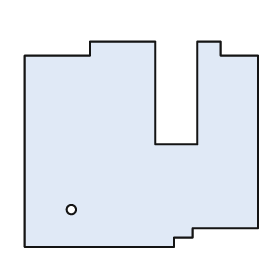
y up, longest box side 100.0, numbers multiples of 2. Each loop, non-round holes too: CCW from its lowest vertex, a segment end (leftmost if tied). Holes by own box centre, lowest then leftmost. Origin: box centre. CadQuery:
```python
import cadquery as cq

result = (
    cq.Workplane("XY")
    .moveTo(-50.0, -44.0)
    .lineTo(14.0, -44.0)
    .lineTo(14.0, -40.0)
    .lineTo(22.0, -40.0)
    .lineTo(22.0, -36.0)
    .lineTo(50.0, -36.0)
    .lineTo(50.0, 38.0)
    .lineTo(34.0, 38.0)
    .lineTo(34.0, 44.0)
    .lineTo(24.0, 44.0)
    .lineTo(24.0, 0.0)
    .lineTo(6.0, 0.0)
    .lineTo(6.0, 44.0)
    .lineTo(-22.0, 44.0)
    .lineTo(-22.0, 38.0)
    .lineTo(-50.0, 38.0)
    .close()
    .moveTo(-30.0, -28.0)
    .circle(2.0)
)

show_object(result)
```